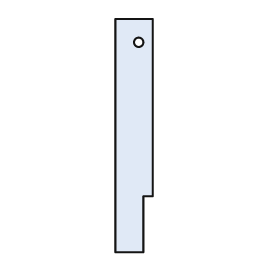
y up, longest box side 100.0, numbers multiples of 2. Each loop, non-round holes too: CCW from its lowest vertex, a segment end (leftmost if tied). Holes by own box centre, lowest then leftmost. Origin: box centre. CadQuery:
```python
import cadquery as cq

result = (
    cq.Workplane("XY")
    .moveTo(-8.0, -50.0)
    .lineTo(4.0, -50.0)
    .lineTo(4.0, -26.0)
    .lineTo(8.0, -26.0)
    .lineTo(8.0, 50.0)
    .lineTo(-8.0, 50.0)
    .close()
    .moveTo(2.0, 40.0)
    .circle(2.0)
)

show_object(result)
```